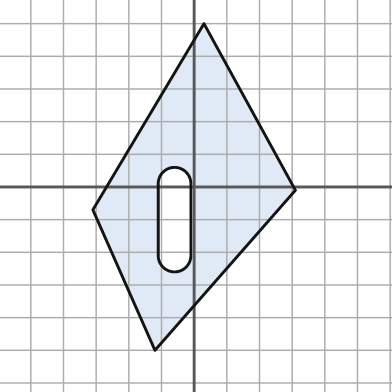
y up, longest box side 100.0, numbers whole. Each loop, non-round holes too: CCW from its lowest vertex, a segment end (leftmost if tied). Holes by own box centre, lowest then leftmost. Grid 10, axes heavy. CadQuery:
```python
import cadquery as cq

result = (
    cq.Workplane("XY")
    .moveTo(-12.0, -50.0)
    .lineTo(31.0, -1.0)
    .lineTo(3.0, 50.0)
    .lineTo(-31.0, -7.0)
    .close()
    .moveTo(-11.0, -21.0)
    .threePointArc((-6.0, -26.0), (-1.0, -21.0))
    .lineTo(-1.0, 1.0)
    .threePointArc((-6.0, 6.0), (-11.0, 1.0))
    .close()
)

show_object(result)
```